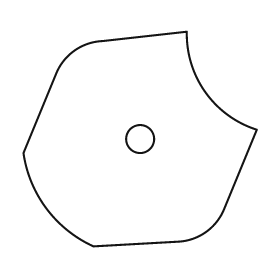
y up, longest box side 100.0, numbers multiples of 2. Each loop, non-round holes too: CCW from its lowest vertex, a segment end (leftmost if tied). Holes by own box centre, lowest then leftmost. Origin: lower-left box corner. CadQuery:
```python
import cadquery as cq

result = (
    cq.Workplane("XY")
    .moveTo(30.0, 0.0)
    .lineTo(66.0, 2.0)
    .threePointArc((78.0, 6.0), (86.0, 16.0))
    .lineTo(100.0, 50.0)
    .threePointArc((78.0, 66.0), (70.0, 92.0))
    .lineTo(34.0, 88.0)
    .threePointArc((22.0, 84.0), (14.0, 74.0))
    .lineTo(0.0, 40.0)
    .threePointArc((10.0, 16.0), (30.0, 0.0))
    .close()
    .moveTo(50.0, 46.0)
    .circle(6.0)
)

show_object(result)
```